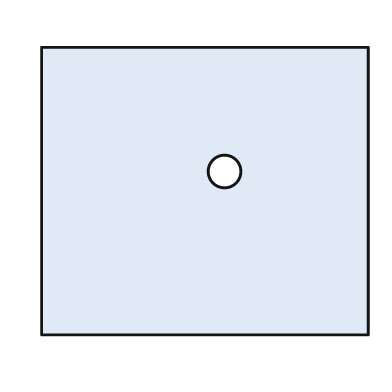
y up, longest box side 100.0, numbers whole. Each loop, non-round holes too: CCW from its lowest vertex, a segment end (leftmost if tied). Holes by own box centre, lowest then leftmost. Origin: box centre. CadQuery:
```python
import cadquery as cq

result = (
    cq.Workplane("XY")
    .moveTo(-50.0, -44.0)
    .lineTo(50.0, -44.0)
    .lineTo(50.0, 44.0)
    .lineTo(-50.0, 44.0)
    .close()
    .moveTo(6.0, 6.0)
    .circle(5.0)
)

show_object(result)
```